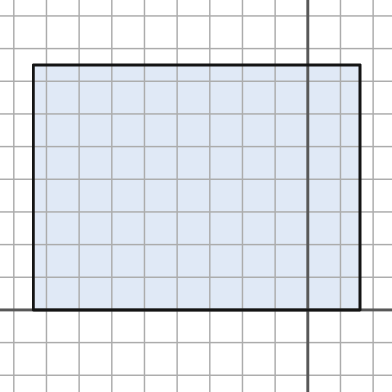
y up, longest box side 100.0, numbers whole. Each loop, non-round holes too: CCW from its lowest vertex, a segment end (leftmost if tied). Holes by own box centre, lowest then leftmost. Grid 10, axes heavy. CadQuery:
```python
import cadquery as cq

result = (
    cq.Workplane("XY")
    .moveTo(-84.0, 0.0)
    .lineTo(16.0, 0.0)
    .lineTo(16.0, 75.0)
    .lineTo(-84.0, 75.0)
    .close()
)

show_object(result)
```